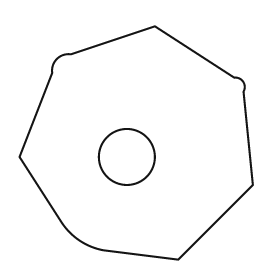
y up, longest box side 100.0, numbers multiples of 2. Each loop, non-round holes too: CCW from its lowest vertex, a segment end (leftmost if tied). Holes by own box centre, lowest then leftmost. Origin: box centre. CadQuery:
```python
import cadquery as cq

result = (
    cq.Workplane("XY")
    .moveTo(18.0, -50.0)
    .lineTo(50.0, -18.0)
    .lineTo(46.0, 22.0)
    .threePointArc((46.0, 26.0), (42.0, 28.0))
    .lineTo(8.0, 50.0)
    .lineTo(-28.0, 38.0)
    .threePointArc((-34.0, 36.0), (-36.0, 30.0))
    .lineTo(-50.0, -6.0)
    .lineTo(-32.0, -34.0)
    .threePointArc((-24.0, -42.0), (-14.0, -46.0))
    .close()
    .moveTo(-4.0, -6.0)
    .circle(12.0)
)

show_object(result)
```